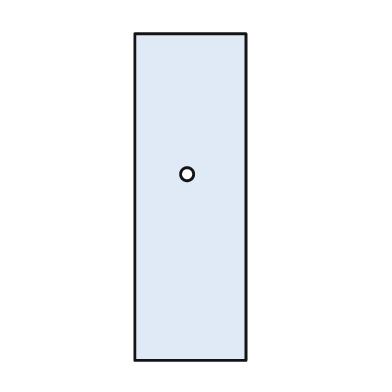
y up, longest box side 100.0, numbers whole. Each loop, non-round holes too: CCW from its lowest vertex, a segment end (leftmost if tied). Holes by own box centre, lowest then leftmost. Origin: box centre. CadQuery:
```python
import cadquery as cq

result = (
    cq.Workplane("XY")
    .moveTo(-17.0, -50.0)
    .lineTo(17.0, -50.0)
    .lineTo(17.0, 50.0)
    .lineTo(-17.0, 50.0)
    .close()
    .moveTo(-1.0, 7.0)
    .circle(2.0)
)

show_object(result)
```